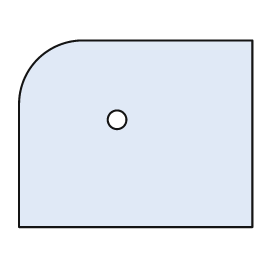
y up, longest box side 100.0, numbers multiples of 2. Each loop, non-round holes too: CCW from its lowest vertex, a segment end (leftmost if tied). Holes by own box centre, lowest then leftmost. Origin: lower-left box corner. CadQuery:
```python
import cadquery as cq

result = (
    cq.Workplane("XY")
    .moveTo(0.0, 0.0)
    .lineTo(100.0, 0.0)
    .lineTo(100.0, 80.0)
    .lineTo(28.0, 80.0)
    .threePointArc((8.0, 72.0), (0.0, 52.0))
    .close()
    .moveTo(42.0, 46.0)
    .circle(4.0)
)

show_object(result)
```